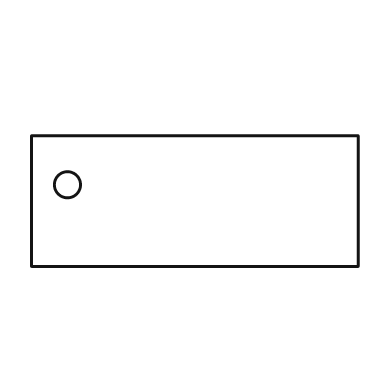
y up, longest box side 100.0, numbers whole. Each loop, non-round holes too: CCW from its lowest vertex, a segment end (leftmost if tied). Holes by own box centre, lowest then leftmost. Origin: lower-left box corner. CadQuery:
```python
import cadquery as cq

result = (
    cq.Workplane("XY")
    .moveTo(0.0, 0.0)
    .lineTo(100.0, 0.0)
    .lineTo(100.0, 40.0)
    .lineTo(0.0, 40.0)
    .close()
    .moveTo(11.0, 25.0)
    .circle(4.0)
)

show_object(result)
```